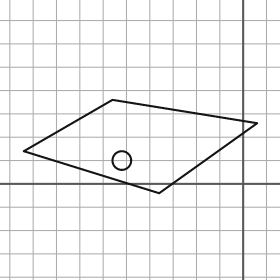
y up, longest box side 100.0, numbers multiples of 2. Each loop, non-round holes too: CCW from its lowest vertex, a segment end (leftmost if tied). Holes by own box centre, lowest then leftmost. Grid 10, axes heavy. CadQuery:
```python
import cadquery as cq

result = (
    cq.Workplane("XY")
    .moveTo(-36.0, -4.0)
    .lineTo(6.0, 26.0)
    .lineTo(-56.0, 36.0)
    .lineTo(-94.0, 14.0)
    .close()
    .moveTo(-52.0, 10.0)
    .circle(4.0)
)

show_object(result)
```